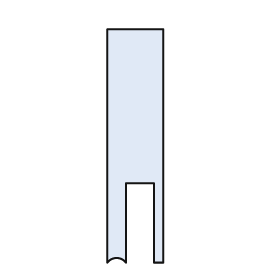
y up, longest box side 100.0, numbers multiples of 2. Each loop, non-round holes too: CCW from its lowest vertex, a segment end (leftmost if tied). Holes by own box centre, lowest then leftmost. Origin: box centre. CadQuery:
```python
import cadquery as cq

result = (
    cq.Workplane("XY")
    .moveTo(-12.0, -50.0)
    .threePointArc((-8.0, -48.0), (-4.0, -50.0))
    .lineTo(-4.0, -16.0)
    .lineTo(8.0, -16.0)
    .lineTo(8.0, -50.0)
    .lineTo(12.0, -50.0)
    .lineTo(12.0, 50.0)
    .lineTo(-12.0, 50.0)
    .close()
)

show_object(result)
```